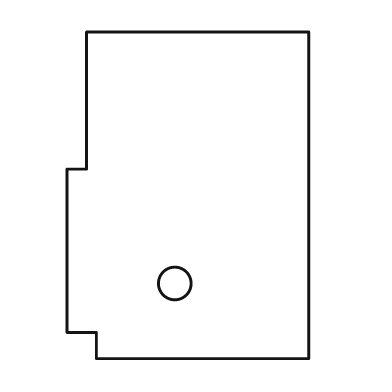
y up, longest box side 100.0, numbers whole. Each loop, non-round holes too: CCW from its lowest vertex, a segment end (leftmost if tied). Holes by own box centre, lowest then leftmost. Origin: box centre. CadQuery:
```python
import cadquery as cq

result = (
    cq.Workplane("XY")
    .moveTo(-28.0, -50.0)
    .lineTo(37.0, -50.0)
    .lineTo(37.0, 50.0)
    .lineTo(-31.0, 50.0)
    .lineTo(-31.0, 8.0)
    .lineTo(-37.0, 8.0)
    .lineTo(-37.0, -42.0)
    .lineTo(-28.0, -42.0)
    .close()
    .moveTo(-4.0, -27.0)
    .circle(5.0)
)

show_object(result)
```